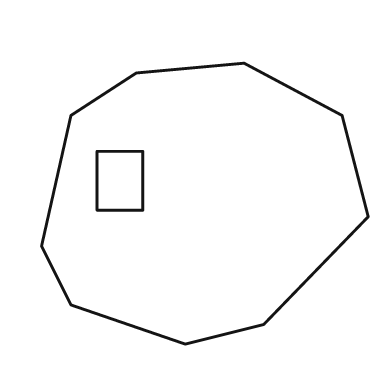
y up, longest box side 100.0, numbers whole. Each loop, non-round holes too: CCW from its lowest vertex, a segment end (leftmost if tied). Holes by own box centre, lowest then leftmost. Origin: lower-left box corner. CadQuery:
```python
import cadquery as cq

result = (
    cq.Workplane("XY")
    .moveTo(44.0, 0.0)
    .lineTo(68.0, 6.0)
    .lineTo(100.0, 39.0)
    .lineTo(92.0, 70.0)
    .lineTo(62.0, 86.0)
    .lineTo(29.0, 83.0)
    .lineTo(9.0, 70.0)
    .lineTo(0.0, 30.0)
    .lineTo(9.0, 12.0)
    .close()
    .moveTo(17.0, 41.0)
    .lineTo(31.0, 41.0)
    .lineTo(31.0, 59.0)
    .lineTo(17.0, 59.0)
    .close()
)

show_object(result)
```